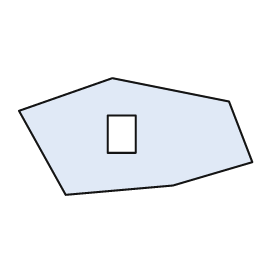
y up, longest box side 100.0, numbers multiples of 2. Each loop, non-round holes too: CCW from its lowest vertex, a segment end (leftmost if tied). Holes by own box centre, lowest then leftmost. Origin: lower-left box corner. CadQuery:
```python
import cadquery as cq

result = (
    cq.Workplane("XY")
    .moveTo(20.0, 0.0)
    .lineTo(66.0, 4.0)
    .lineTo(100.0, 14.0)
    .lineTo(90.0, 40.0)
    .lineTo(40.0, 50.0)
    .lineTo(0.0, 36.0)
    .close()
    .moveTo(38.0, 18.0)
    .lineTo(50.0, 18.0)
    .lineTo(50.0, 34.0)
    .lineTo(38.0, 34.0)
    .close()
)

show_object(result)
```